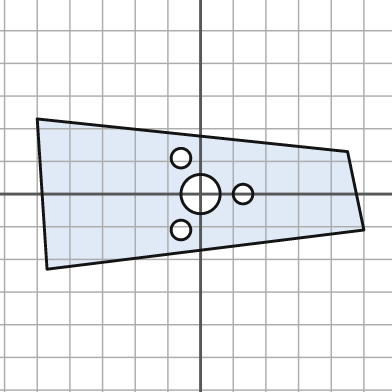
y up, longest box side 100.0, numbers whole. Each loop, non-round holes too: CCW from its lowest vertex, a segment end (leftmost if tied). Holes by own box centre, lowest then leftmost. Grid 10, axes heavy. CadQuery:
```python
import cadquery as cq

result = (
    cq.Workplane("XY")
    .moveTo(-47.0, -23.0)
    .lineTo(50.0, -11.0)
    .lineTo(45.0, 13.0)
    .lineTo(-50.0, 23.0)
    .close()
    .moveTo(-6.0, -11.0)
    .circle(3.0)
    .moveTo(0.0, 0.0)
    .circle(6.0)
    .moveTo(13.0, 0.0)
    .circle(3.0)
    .moveTo(-6.0, 11.0)
    .circle(3.0)
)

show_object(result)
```